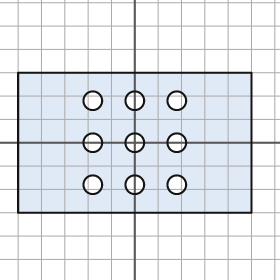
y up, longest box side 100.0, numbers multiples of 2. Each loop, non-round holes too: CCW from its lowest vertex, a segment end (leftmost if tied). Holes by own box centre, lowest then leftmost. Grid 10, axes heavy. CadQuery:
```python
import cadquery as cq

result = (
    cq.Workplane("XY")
    .moveTo(-50.0, -30.0)
    .lineTo(50.0, -30.0)
    .lineTo(50.0, 30.0)
    .lineTo(-50.0, 30.0)
    .close()
    .moveTo(-18.0, -18.0)
    .circle(4.0)
    .moveTo(0.0, -18.0)
    .circle(4.0)
    .moveTo(18.0, -18.0)
    .circle(4.0)
    .moveTo(-18.0, 0.0)
    .circle(4.0)
    .moveTo(0.0, 0.0)
    .circle(4.0)
    .moveTo(18.0, 0.0)
    .circle(4.0)
    .moveTo(-18.0, 18.0)
    .circle(4.0)
    .moveTo(0.0, 18.0)
    .circle(4.0)
    .moveTo(18.0, 18.0)
    .circle(4.0)
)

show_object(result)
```